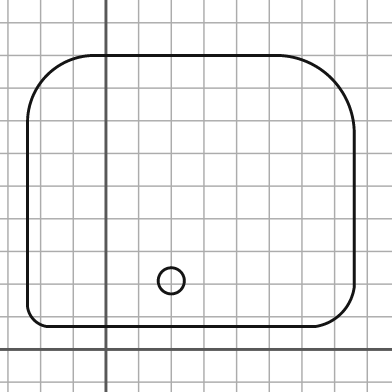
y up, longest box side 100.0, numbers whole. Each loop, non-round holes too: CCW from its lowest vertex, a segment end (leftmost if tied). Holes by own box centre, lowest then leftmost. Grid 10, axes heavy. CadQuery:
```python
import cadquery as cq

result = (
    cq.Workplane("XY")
    .moveTo(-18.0, 7.0)
    .lineTo(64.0, 7.0)
    .threePointArc((72.0, 11.0), (76.0, 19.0))
    .lineTo(76.0, 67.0)
    .threePointArc((69.0, 83.0), (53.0, 90.0))
    .lineTo(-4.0, 90.0)
    .threePointArc((-18.0, 84.0), (-24.0, 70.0))
    .lineTo(-24.0, 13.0)
    .threePointArc((-22.0, 9.0), (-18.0, 7.0))
    .close()
    .moveTo(20.0, 21.0)
    .circle(4.0)
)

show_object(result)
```